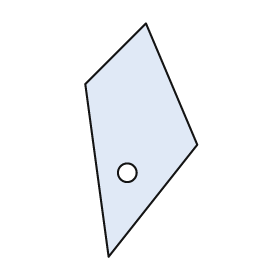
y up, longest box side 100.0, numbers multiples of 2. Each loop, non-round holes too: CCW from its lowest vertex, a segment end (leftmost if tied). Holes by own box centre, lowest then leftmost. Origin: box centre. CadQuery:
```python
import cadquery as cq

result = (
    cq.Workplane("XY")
    .moveTo(-14.0, -50.0)
    .lineTo(24.0, -2.0)
    .lineTo(2.0, 50.0)
    .lineTo(-24.0, 24.0)
    .close()
    .moveTo(-6.0, -14.0)
    .circle(4.0)
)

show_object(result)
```